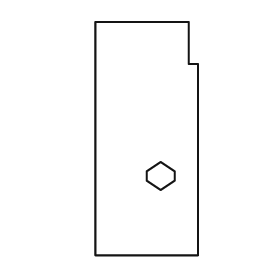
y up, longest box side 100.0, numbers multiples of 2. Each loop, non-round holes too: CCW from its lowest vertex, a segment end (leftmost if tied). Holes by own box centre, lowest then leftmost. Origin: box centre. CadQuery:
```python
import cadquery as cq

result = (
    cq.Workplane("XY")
    .moveTo(-22.0, -50.0)
    .lineTo(22.0, -50.0)
    .lineTo(22.0, 32.0)
    .lineTo(18.0, 32.0)
    .lineTo(18.0, 50.0)
    .lineTo(-22.0, 50.0)
    .close()
    .moveTo(6.0, -22.0)
    .lineTo(12.0, -18.0)
    .lineTo(12.0, -14.0)
    .lineTo(6.0, -10.0)
    .lineTo(0.0, -14.0)
    .lineTo(0.0, -18.0)
    .close()
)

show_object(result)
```